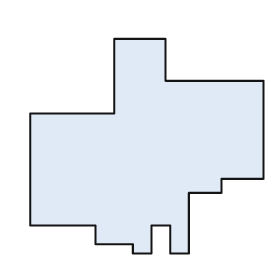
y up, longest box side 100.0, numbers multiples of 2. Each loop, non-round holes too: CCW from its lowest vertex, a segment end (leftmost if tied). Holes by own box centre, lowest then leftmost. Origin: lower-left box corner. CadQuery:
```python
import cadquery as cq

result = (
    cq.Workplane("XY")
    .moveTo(44.0, 0.0)
    .lineTo(52.0, 0.0)
    .lineTo(52.0, 12.0)
    .lineTo(60.0, 12.0)
    .lineTo(60.0, 0.0)
    .lineTo(68.0, 0.0)
    .lineTo(68.0, 26.0)
    .lineTo(82.0, 26.0)
    .lineTo(82.0, 32.0)
    .lineTo(100.0, 32.0)
    .lineTo(100.0, 74.0)
    .lineTo(58.0, 74.0)
    .lineTo(58.0, 92.0)
    .lineTo(36.0, 92.0)
    .lineTo(36.0, 60.0)
    .lineTo(0.0, 60.0)
    .lineTo(0.0, 12.0)
    .lineTo(28.0, 12.0)
    .lineTo(28.0, 4.0)
    .lineTo(44.0, 4.0)
    .close()
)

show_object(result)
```